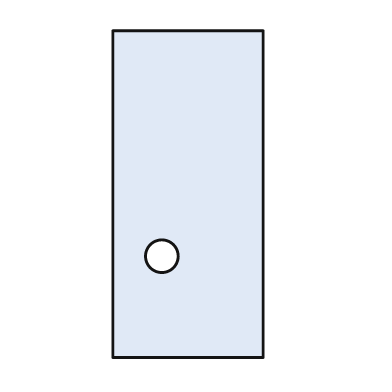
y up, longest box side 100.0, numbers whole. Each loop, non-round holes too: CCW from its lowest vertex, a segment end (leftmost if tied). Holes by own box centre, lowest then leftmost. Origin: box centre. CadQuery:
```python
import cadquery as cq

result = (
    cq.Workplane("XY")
    .moveTo(-23.0, -50.0)
    .lineTo(23.0, -50.0)
    .lineTo(23.0, 50.0)
    .lineTo(-23.0, 50.0)
    .close()
    .moveTo(-8.0, -19.0)
    .circle(5.0)
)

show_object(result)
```